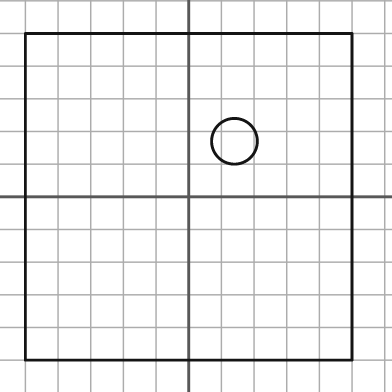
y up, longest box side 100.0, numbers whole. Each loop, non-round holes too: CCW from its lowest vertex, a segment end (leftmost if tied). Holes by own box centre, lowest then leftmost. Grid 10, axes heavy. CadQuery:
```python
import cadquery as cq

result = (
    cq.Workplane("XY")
    .moveTo(-50.0, -50.0)
    .lineTo(50.0, -50.0)
    .lineTo(50.0, 50.0)
    .lineTo(-50.0, 50.0)
    .close()
    .moveTo(14.0, 17.0)
    .circle(7.0)
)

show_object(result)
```